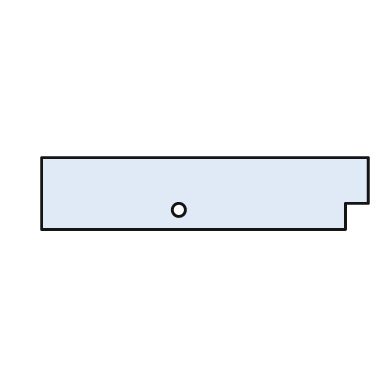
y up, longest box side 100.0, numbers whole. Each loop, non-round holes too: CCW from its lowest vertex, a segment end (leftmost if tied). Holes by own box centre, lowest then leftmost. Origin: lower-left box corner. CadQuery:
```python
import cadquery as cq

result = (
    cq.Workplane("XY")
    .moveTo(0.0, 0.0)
    .lineTo(93.0, 0.0)
    .lineTo(93.0, 8.0)
    .lineTo(100.0, 8.0)
    .lineTo(100.0, 22.0)
    .lineTo(0.0, 22.0)
    .close()
    .moveTo(42.0, 6.0)
    .circle(2.0)
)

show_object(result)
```